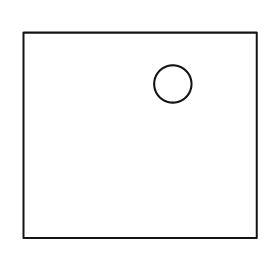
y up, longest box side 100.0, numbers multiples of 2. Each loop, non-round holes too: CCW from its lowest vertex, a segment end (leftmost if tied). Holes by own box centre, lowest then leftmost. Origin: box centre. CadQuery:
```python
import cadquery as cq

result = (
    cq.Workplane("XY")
    .moveTo(-50.0, -44.0)
    .lineTo(50.0, -44.0)
    .lineTo(50.0, 44.0)
    .lineTo(-50.0, 44.0)
    .close()
    .moveTo(14.0, 22.0)
    .circle(8.0)
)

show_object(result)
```